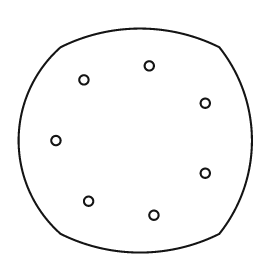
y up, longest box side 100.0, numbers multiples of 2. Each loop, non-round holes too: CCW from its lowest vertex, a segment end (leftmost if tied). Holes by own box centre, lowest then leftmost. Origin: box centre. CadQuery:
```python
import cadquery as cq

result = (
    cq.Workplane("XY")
    .moveTo(-32.0, -40.0)
    .threePointArc((2.0, -48.0), (36.0, -40.0))
    .threePointArc((50.0, 0.0), (36.0, 40.0))
    .threePointArc((2.0, 48.0), (-32.0, 40.0))
    .threePointArc((-50.0, 0.0), (-32.0, -40.0))
    .close()
    .moveTo(8.0, -32.0)
    .circle(2.0)
    .moveTo(-20.0, -26.0)
    .circle(2.0)
    .moveTo(30.0, -14.0)
    .circle(2.0)
    .moveTo(-34.0, 0.0)
    .circle(2.0)
    .moveTo(30.0, 16.0)
    .circle(2.0)
    .moveTo(-22.0, 26.0)
    .circle(2.0)
    .moveTo(6.0, 32.0)
    .circle(2.0)
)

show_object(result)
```